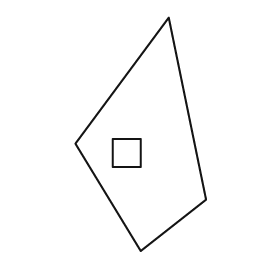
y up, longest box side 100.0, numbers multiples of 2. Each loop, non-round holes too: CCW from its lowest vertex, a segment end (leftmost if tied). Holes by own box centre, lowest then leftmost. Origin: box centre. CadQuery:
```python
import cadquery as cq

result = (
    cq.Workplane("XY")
    .moveTo(0.0, -50.0)
    .lineTo(28.0, -28.0)
    .lineTo(12.0, 50.0)
    .lineTo(-28.0, -4.0)
    .close()
    .moveTo(-12.0, -14.0)
    .lineTo(0.0, -14.0)
    .lineTo(0.0, -2.0)
    .lineTo(-12.0, -2.0)
    .close()
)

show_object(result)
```